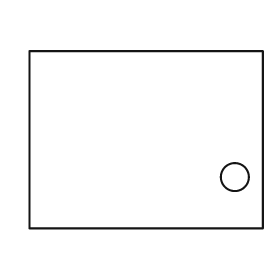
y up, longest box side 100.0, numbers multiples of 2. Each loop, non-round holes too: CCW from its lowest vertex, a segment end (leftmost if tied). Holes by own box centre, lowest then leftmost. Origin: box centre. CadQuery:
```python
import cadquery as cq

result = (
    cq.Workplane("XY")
    .moveTo(-50.0, -38.0)
    .lineTo(50.0, -38.0)
    .lineTo(50.0, 38.0)
    .lineTo(-50.0, 38.0)
    .close()
    .moveTo(38.0, -16.0)
    .circle(6.0)
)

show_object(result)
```